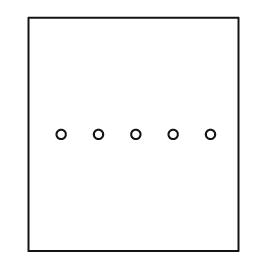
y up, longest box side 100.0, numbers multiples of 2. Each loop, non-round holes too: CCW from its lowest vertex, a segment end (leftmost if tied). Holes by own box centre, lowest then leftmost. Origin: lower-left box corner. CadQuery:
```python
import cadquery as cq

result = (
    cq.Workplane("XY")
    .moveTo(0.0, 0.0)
    .lineTo(90.0, 0.0)
    .lineTo(90.0, 100.0)
    .lineTo(0.0, 100.0)
    .close()
    .moveTo(14.0, 50.0)
    .circle(2.0)
    .moveTo(30.0, 50.0)
    .circle(2.0)
    .moveTo(46.0, 50.0)
    .circle(2.0)
    .moveTo(62.0, 50.0)
    .circle(2.0)
    .moveTo(78.0, 50.0)
    .circle(2.0)
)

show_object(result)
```